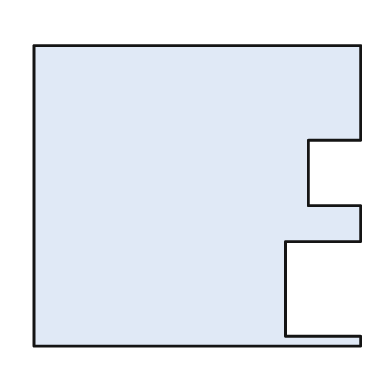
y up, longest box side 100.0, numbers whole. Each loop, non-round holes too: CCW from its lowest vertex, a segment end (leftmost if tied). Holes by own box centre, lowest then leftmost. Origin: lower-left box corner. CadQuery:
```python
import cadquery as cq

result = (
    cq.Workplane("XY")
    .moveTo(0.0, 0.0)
    .lineTo(100.0, 0.0)
    .lineTo(100.0, 3.0)
    .lineTo(77.0, 3.0)
    .lineTo(77.0, 32.0)
    .lineTo(100.0, 32.0)
    .lineTo(100.0, 43.0)
    .lineTo(84.0, 43.0)
    .lineTo(84.0, 63.0)
    .lineTo(100.0, 63.0)
    .lineTo(100.0, 92.0)
    .lineTo(0.0, 92.0)
    .close()
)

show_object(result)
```